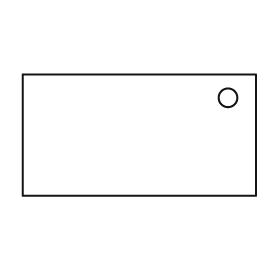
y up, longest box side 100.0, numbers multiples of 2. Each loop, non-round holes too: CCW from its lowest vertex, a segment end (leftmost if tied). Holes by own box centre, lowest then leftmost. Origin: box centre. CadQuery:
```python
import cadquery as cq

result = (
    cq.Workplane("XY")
    .moveTo(-50.0, -26.0)
    .lineTo(50.0, -26.0)
    .lineTo(50.0, 26.0)
    .lineTo(-50.0, 26.0)
    .close()
    .moveTo(38.0, 16.0)
    .circle(4.0)
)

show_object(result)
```